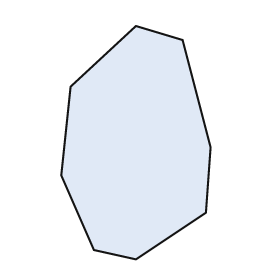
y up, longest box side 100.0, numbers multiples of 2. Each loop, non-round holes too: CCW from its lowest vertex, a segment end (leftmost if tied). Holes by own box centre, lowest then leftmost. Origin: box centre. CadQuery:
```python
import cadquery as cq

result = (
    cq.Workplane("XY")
    .moveTo(0.0, -50.0)
    .lineTo(30.0, -30.0)
    .lineTo(32.0, -2.0)
    .lineTo(20.0, 44.0)
    .lineTo(0.0, 50.0)
    .lineTo(-28.0, 24.0)
    .lineTo(-32.0, -14.0)
    .lineTo(-18.0, -46.0)
    .close()
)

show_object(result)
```